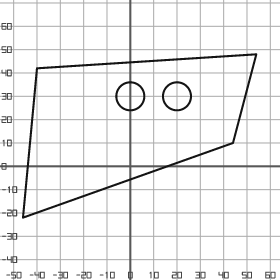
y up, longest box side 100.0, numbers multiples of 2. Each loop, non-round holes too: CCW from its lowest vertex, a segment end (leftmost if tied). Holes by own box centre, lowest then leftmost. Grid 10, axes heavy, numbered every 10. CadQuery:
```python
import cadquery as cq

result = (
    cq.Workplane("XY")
    .moveTo(-46.0, -22.0)
    .lineTo(44.0, 10.0)
    .lineTo(54.0, 48.0)
    .lineTo(-40.0, 42.0)
    .close()
    .moveTo(0.0, 30.0)
    .circle(6.0)
    .moveTo(20.0, 30.0)
    .circle(6.0)
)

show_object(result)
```